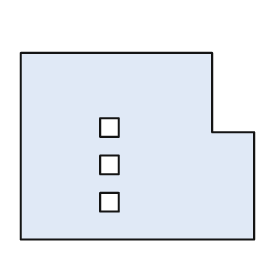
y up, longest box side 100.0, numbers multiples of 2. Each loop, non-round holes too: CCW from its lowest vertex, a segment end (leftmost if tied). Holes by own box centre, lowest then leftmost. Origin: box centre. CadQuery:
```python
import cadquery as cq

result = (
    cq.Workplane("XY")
    .moveTo(-50.0, -40.0)
    .lineTo(50.0, -40.0)
    .lineTo(50.0, 6.0)
    .lineTo(32.0, 6.0)
    .lineTo(32.0, 40.0)
    .lineTo(-50.0, 40.0)
    .close()
    .moveTo(-16.0, -28.0)
    .lineTo(-8.0, -28.0)
    .lineTo(-8.0, -20.0)
    .lineTo(-16.0, -20.0)
    .close()
    .moveTo(-16.0, -12.0)
    .lineTo(-8.0, -12.0)
    .lineTo(-8.0, -4.0)
    .lineTo(-16.0, -4.0)
    .close()
    .moveTo(-16.0, 4.0)
    .lineTo(-8.0, 4.0)
    .lineTo(-8.0, 12.0)
    .lineTo(-16.0, 12.0)
    .close()
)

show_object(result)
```